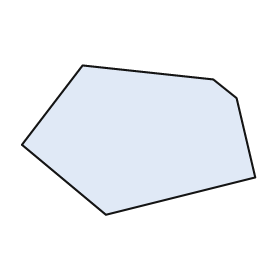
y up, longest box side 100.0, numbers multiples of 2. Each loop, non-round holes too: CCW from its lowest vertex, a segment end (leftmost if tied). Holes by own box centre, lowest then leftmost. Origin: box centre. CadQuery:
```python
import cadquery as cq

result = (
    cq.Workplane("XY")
    .moveTo(-14.0, -32.0)
    .lineTo(50.0, -16.0)
    .lineTo(42.0, 18.0)
    .lineTo(32.0, 26.0)
    .lineTo(-24.0, 32.0)
    .lineTo(-50.0, -2.0)
    .close()
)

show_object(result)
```